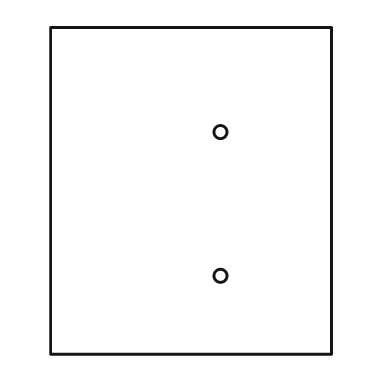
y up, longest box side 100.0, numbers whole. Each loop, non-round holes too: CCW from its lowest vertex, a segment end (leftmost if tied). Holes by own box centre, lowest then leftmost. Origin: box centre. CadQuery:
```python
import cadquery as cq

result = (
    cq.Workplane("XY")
    .moveTo(-43.0, -50.0)
    .lineTo(43.0, -50.0)
    .lineTo(43.0, 50.0)
    .lineTo(-43.0, 50.0)
    .close()
    .moveTo(9.0, -26.0)
    .circle(2.0)
    .moveTo(9.0, 18.0)
    .circle(2.0)
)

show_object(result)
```